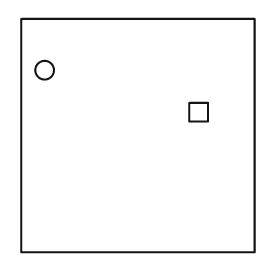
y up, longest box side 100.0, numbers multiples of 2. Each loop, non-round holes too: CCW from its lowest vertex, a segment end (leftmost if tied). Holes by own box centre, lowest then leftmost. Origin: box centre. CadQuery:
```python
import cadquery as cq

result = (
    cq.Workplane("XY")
    .moveTo(-50.0, -50.0)
    .lineTo(50.0, -50.0)
    .lineTo(50.0, 50.0)
    .lineTo(-50.0, 50.0)
    .close()
    .moveTo(22.0, 6.0)
    .lineTo(30.0, 6.0)
    .lineTo(30.0, 14.0)
    .lineTo(22.0, 14.0)
    .close()
    .moveTo(-40.0, 28.0)
    .circle(4.0)
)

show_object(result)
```